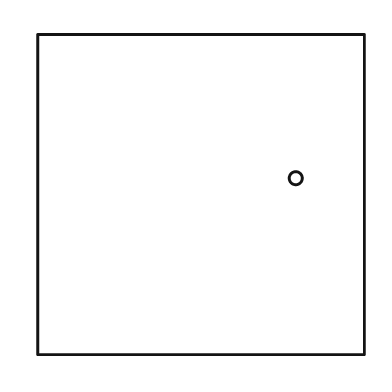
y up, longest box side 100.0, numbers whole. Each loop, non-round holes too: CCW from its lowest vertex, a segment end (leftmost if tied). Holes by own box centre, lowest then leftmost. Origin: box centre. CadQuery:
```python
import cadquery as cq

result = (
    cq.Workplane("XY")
    .moveTo(-50.0, -49.0)
    .lineTo(50.0, -49.0)
    .lineTo(50.0, 49.0)
    .lineTo(-50.0, 49.0)
    .close()
    .moveTo(29.0, 5.0)
    .circle(2.0)
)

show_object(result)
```